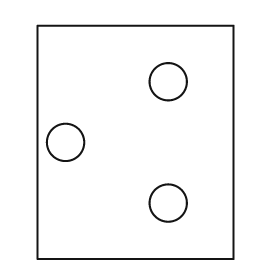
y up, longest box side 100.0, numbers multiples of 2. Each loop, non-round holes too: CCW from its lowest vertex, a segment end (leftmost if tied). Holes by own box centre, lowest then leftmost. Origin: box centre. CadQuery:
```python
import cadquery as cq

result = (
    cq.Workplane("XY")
    .moveTo(-42.0, -50.0)
    .lineTo(42.0, -50.0)
    .lineTo(42.0, 50.0)
    .lineTo(-42.0, 50.0)
    .close()
    .moveTo(14.0, -26.0)
    .circle(8.0)
    .moveTo(-30.0, 0.0)
    .circle(8.0)
    .moveTo(14.0, 26.0)
    .circle(8.0)
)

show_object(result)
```